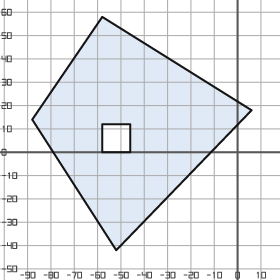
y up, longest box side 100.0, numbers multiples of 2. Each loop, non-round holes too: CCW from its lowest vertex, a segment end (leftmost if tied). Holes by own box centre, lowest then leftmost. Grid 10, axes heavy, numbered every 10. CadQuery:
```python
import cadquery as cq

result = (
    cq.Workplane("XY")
    .moveTo(-52.0, -42.0)
    .lineTo(6.0, 18.0)
    .lineTo(-58.0, 58.0)
    .lineTo(-88.0, 14.0)
    .close()
    .moveTo(-58.0, 0.0)
    .lineTo(-46.0, 0.0)
    .lineTo(-46.0, 12.0)
    .lineTo(-58.0, 12.0)
    .close()
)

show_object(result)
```